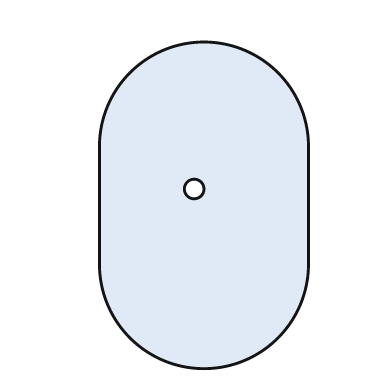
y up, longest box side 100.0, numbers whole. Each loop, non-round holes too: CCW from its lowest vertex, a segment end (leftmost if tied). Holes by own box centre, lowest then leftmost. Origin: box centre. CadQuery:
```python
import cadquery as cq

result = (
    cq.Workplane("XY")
    .moveTo(-32.0, -18.0)
    .threePointArc((0.0, -50.0), (32.0, -18.0))
    .lineTo(32.0, 18.0)
    .threePointArc((0.0, 50.0), (-32.0, 18.0))
    .close()
    .moveTo(-3.0, 5.0)
    .circle(3.0)
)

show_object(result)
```